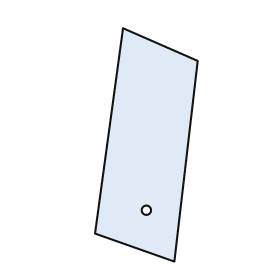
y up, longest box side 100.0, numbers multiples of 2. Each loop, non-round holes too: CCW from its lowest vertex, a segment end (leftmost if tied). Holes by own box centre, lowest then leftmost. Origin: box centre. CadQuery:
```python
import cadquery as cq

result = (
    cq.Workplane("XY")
    .moveTo(12.0, -50.0)
    .lineTo(22.0, 36.0)
    .lineTo(-10.0, 50.0)
    .lineTo(-22.0, -38.0)
    .close()
    .moveTo(0.0, -28.0)
    .circle(2.0)
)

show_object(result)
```